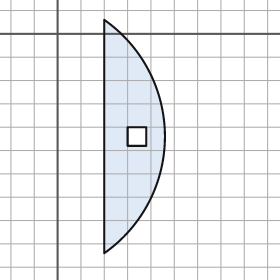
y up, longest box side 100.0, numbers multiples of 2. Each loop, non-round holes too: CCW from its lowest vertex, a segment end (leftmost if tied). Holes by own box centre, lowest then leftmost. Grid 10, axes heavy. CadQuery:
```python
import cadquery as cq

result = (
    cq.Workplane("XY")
    .moveTo(20.0, -94.0)
    .threePointArc((46.0, -44.0), (20.0, 6.0))
    .close()
    .moveTo(30.0, -48.0)
    .lineTo(38.0, -48.0)
    .lineTo(38.0, -40.0)
    .lineTo(30.0, -40.0)
    .close()
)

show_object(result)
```